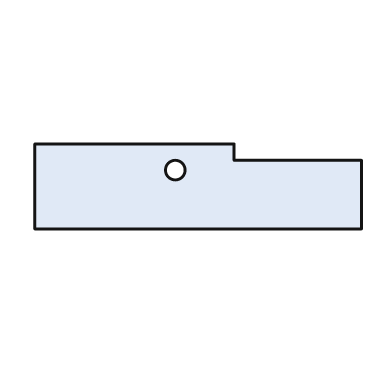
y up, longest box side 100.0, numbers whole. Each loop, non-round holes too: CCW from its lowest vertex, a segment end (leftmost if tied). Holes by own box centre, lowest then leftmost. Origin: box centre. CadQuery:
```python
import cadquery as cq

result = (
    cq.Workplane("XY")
    .moveTo(-50.0, -13.0)
    .lineTo(50.0, -13.0)
    .lineTo(50.0, 8.0)
    .lineTo(11.0, 8.0)
    .lineTo(11.0, 13.0)
    .lineTo(-50.0, 13.0)
    .close()
    .moveTo(-7.0, 5.0)
    .circle(3.0)
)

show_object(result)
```